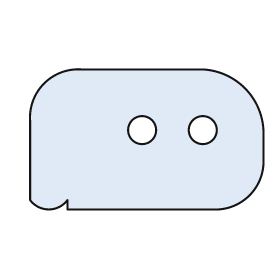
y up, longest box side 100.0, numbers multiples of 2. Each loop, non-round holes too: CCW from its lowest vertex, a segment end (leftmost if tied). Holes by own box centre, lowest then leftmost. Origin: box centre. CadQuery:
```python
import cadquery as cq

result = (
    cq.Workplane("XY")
    .moveTo(-34.0, -30.0)
    .lineTo(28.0, -30.0)
    .threePointArc((44.0, -24.0), (50.0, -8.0))
    .lineTo(50.0, 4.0)
    .threePointArc((42.0, 22.0), (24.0, 30.0))
    .lineTo(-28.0, 30.0)
    .threePointArc((-44.0, 24.0), (-50.0, 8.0))
    .lineTo(-50.0, -26.0)
    .threePointArc((-42.0, -30.0), (-34.0, -26.0))
    .close()
    .moveTo(-2.0, 4.0)
    .circle(6.0)
    .moveTo(24.0, 4.0)
    .circle(6.0)
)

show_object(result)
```